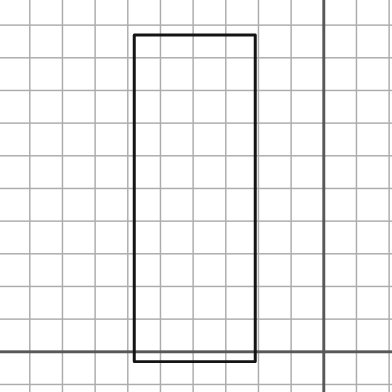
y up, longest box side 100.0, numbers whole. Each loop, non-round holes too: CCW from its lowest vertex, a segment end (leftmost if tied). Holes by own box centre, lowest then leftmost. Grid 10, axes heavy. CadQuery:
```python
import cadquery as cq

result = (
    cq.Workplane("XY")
    .moveTo(-58.0, -3.0)
    .lineTo(-21.0, -3.0)
    .lineTo(-21.0, 97.0)
    .lineTo(-58.0, 97.0)
    .close()
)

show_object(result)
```